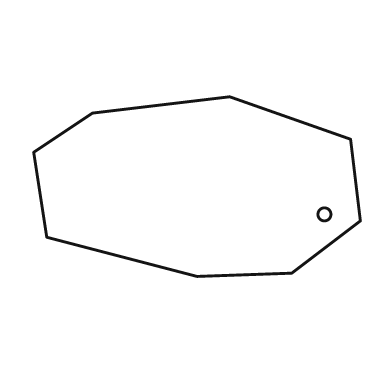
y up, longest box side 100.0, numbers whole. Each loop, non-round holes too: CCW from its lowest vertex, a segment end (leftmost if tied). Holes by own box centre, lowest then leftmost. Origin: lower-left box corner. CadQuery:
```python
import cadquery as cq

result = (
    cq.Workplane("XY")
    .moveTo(50.0, 0.0)
    .lineTo(79.0, 1.0)
    .lineTo(100.0, 17.0)
    .lineTo(97.0, 42.0)
    .lineTo(60.0, 55.0)
    .lineTo(18.0, 50.0)
    .lineTo(0.0, 38.0)
    .lineTo(4.0, 12.0)
    .close()
    .moveTo(89.0, 19.0)
    .circle(2.0)
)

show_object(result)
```